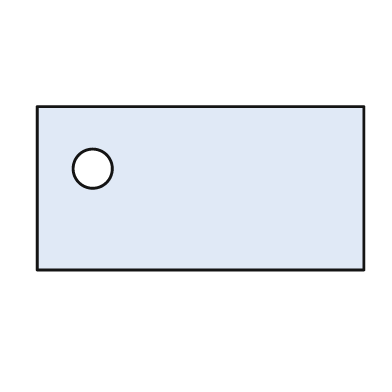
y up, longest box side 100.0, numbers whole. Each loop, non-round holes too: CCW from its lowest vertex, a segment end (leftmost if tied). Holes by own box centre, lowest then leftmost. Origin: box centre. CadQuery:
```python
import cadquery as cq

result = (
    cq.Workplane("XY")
    .moveTo(-50.0, -25.0)
    .lineTo(50.0, -25.0)
    .lineTo(50.0, 25.0)
    .lineTo(-50.0, 25.0)
    .close()
    .moveTo(-33.0, 6.0)
    .circle(6.0)
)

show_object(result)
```